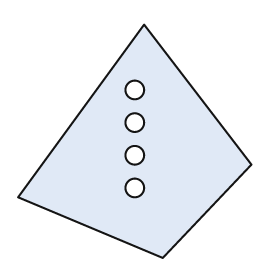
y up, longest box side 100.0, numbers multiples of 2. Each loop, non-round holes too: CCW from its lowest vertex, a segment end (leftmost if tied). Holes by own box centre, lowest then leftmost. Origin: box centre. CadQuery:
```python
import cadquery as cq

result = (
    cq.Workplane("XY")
    .moveTo(12.0, -50.0)
    .lineTo(50.0, -10.0)
    .lineTo(4.0, 50.0)
    .lineTo(-50.0, -24.0)
    .close()
    .moveTo(0.0, -20.0)
    .circle(4.0)
    .moveTo(0.0, -6.0)
    .circle(4.0)
    .moveTo(0.0, 8.0)
    .circle(4.0)
    .moveTo(0.0, 22.0)
    .circle(4.0)
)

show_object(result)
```